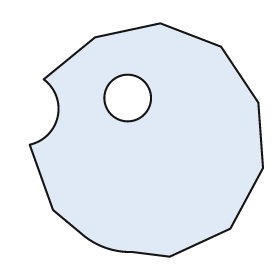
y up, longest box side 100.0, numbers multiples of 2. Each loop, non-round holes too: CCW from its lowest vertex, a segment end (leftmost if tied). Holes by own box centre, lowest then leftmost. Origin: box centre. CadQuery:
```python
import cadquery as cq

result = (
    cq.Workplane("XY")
    .moveTo(10.0, -50.0)
    .lineTo(36.0, -38.0)
    .lineTo(50.0, -12.0)
    .lineTo(48.0, 16.0)
    .lineTo(32.0, 40.0)
    .lineTo(6.0, 50.0)
    .lineTo(-22.0, 44.0)
    .lineTo(-44.0, 26.0)
    .threePointArc((-38.0, 10.0), (-50.0, -2.0))
    .lineTo(-40.0, -30.0)
    .lineTo(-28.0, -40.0)
    .threePointArc((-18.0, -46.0), (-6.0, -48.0))
    .close()
    .moveTo(-8.0, 18.0)
    .circle(10.0)
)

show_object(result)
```